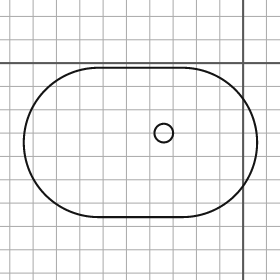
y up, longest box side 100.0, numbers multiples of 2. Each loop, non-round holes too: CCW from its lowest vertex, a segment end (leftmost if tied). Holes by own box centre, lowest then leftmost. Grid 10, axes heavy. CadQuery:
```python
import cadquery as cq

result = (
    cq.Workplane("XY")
    .moveTo(-62.0, -66.0)
    .lineTo(-26.0, -66.0)
    .threePointArc((6.0, -34.0), (-26.0, -2.0))
    .lineTo(-62.0, -2.0)
    .threePointArc((-94.0, -34.0), (-62.0, -66.0))
    .close()
    .moveTo(-34.0, -30.0)
    .circle(4.0)
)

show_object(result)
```